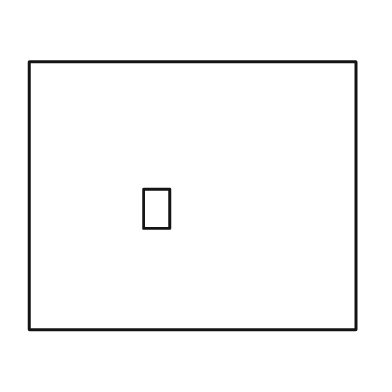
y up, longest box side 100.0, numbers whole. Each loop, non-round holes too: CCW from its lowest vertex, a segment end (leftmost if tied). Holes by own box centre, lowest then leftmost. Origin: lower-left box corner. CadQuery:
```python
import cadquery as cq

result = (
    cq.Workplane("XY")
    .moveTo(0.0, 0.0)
    .lineTo(100.0, 0.0)
    .lineTo(100.0, 82.0)
    .lineTo(0.0, 82.0)
    .close()
    .moveTo(35.0, 31.0)
    .lineTo(43.0, 31.0)
    .lineTo(43.0, 43.0)
    .lineTo(35.0, 43.0)
    .close()
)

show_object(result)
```